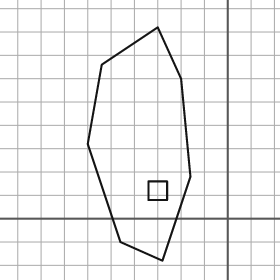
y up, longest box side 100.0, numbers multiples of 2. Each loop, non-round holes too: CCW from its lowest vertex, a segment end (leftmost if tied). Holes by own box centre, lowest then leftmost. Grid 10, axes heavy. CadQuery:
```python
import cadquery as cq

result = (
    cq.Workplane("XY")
    .moveTo(-28.0, -18.0)
    .lineTo(-16.0, 18.0)
    .lineTo(-20.0, 60.0)
    .lineTo(-30.0, 82.0)
    .lineTo(-54.0, 66.0)
    .lineTo(-60.0, 32.0)
    .lineTo(-46.0, -10.0)
    .close()
    .moveTo(-34.0, 8.0)
    .lineTo(-26.0, 8.0)
    .lineTo(-26.0, 16.0)
    .lineTo(-34.0, 16.0)
    .close()
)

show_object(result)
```